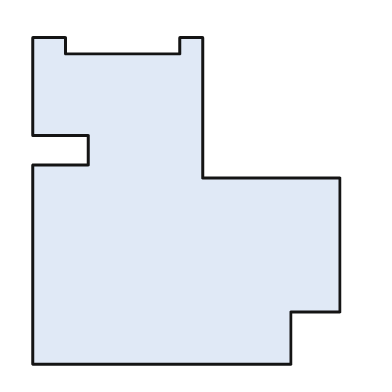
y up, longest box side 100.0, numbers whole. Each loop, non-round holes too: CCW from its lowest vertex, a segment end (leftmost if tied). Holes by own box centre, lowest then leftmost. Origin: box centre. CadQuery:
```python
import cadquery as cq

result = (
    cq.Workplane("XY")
    .moveTo(-47.0, -50.0)
    .lineTo(32.0, -50.0)
    .lineTo(32.0, -34.0)
    .lineTo(47.0, -34.0)
    .lineTo(47.0, 7.0)
    .lineTo(5.0, 7.0)
    .lineTo(5.0, 50.0)
    .lineTo(-2.0, 50.0)
    .lineTo(-2.0, 45.0)
    .lineTo(-37.0, 45.0)
    .lineTo(-37.0, 50.0)
    .lineTo(-47.0, 50.0)
    .lineTo(-47.0, 20.0)
    .lineTo(-30.0, 20.0)
    .lineTo(-30.0, 11.0)
    .lineTo(-47.0, 11.0)
    .close()
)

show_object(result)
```